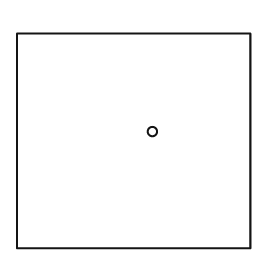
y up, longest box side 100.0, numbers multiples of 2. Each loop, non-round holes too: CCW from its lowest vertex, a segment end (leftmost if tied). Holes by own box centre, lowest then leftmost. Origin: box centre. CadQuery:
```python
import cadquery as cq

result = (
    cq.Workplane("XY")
    .moveTo(-50.0, -46.0)
    .lineTo(50.0, -46.0)
    .lineTo(50.0, 46.0)
    .lineTo(-50.0, 46.0)
    .close()
    .moveTo(8.0, 4.0)
    .circle(2.0)
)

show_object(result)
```